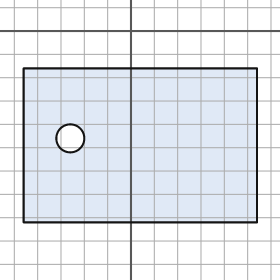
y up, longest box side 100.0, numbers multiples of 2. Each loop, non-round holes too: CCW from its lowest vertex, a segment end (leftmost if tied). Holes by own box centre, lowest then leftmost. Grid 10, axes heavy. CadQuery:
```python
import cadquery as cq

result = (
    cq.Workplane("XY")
    .moveTo(-46.0, -82.0)
    .lineTo(54.0, -82.0)
    .lineTo(54.0, -16.0)
    .lineTo(-46.0, -16.0)
    .close()
    .moveTo(-26.0, -46.0)
    .circle(6.0)
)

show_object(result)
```